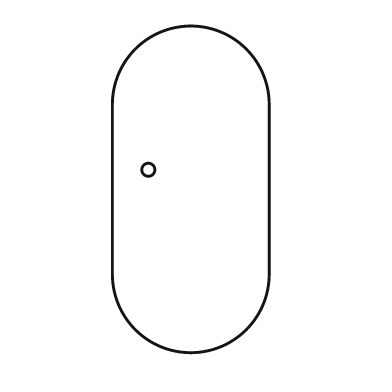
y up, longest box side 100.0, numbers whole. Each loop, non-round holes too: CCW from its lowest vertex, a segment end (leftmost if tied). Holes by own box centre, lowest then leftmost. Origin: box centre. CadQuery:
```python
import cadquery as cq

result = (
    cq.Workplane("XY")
    .moveTo(-24.0, -26.0)
    .threePointArc((0.0, -50.0), (24.0, -26.0))
    .lineTo(24.0, 26.0)
    .threePointArc((0.0, 50.0), (-24.0, 26.0))
    .close()
    .moveTo(-13.0, 6.0)
    .circle(2.0)
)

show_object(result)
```